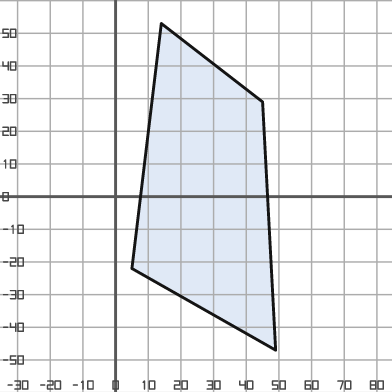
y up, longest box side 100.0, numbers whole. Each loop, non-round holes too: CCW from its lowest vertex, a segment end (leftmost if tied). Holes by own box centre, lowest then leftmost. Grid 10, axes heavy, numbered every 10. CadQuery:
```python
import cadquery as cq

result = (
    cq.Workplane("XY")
    .moveTo(49.0, -47.0)
    .lineTo(45.0, 29.0)
    .lineTo(14.0, 53.0)
    .lineTo(5.0, -22.0)
    .close()
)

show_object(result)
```